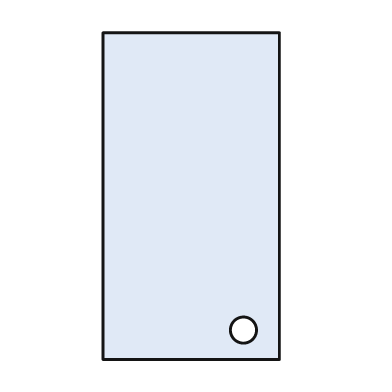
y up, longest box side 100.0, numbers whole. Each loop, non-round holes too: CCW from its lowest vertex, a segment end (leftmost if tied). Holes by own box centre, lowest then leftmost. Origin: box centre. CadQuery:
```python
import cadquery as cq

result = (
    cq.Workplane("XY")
    .moveTo(-27.0, -50.0)
    .lineTo(27.0, -50.0)
    .lineTo(27.0, 50.0)
    .lineTo(-27.0, 50.0)
    .close()
    .moveTo(16.0, -41.0)
    .circle(4.0)
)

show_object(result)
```